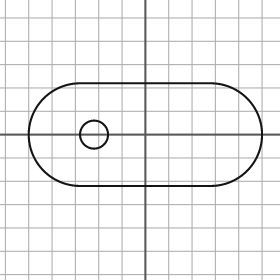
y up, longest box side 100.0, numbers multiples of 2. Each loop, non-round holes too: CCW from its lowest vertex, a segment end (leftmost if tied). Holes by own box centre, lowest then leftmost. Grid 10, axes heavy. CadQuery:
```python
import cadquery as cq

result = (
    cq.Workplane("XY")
    .moveTo(-28.0, -22.0)
    .lineTo(28.0, -22.0)
    .threePointArc((50.0, 0.0), (28.0, 22.0))
    .lineTo(-28.0, 22.0)
    .threePointArc((-50.0, 0.0), (-28.0, -22.0))
    .close()
    .moveTo(-22.0, 0.0)
    .circle(6.0)
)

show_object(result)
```